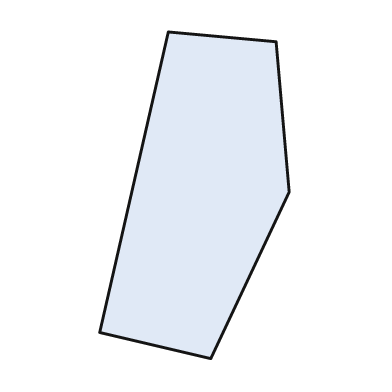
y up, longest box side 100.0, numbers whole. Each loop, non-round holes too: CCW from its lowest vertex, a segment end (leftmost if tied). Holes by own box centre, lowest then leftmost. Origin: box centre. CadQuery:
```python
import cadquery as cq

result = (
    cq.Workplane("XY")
    .moveTo(5.0, -50.0)
    .lineTo(29.0, 1.0)
    .lineTo(25.0, 47.0)
    .lineTo(-8.0, 50.0)
    .lineTo(-29.0, -42.0)
    .close()
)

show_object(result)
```